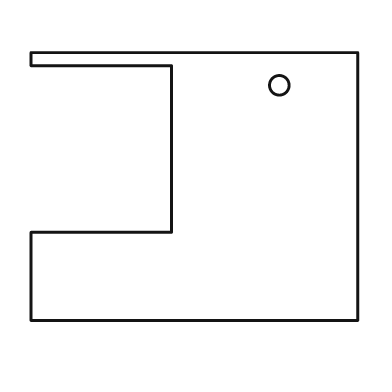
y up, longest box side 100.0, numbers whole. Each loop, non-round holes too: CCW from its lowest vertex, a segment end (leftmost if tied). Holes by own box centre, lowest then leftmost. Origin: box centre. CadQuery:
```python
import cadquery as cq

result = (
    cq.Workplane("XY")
    .moveTo(-50.0, -41.0)
    .lineTo(50.0, -41.0)
    .lineTo(50.0, 41.0)
    .lineTo(-50.0, 41.0)
    .lineTo(-50.0, 37.0)
    .lineTo(-7.0, 37.0)
    .lineTo(-7.0, -14.0)
    .lineTo(-50.0, -14.0)
    .close()
    .moveTo(26.0, 31.0)
    .circle(3.0)
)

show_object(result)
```